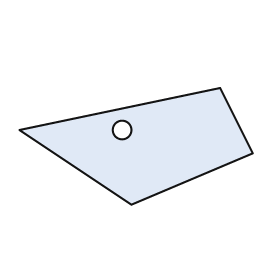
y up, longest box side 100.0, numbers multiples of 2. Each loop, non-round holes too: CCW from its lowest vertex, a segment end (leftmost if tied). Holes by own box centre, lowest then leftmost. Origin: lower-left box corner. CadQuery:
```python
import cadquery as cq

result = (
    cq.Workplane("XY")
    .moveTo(48.0, 0.0)
    .lineTo(100.0, 22.0)
    .lineTo(86.0, 50.0)
    .lineTo(0.0, 32.0)
    .close()
    .moveTo(44.0, 32.0)
    .circle(4.0)
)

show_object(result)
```